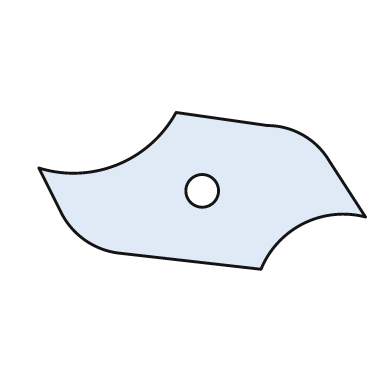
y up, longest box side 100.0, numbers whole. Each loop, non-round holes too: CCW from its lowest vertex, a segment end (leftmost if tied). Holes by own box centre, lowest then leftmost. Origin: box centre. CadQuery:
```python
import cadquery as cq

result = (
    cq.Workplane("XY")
    .moveTo(18.0, -24.0)
    .threePointArc((31.0, -10.0), (50.0, -8.0))
    .lineTo(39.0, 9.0)
    .threePointArc((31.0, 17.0), (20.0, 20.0))
    .lineTo(-8.0, 24.0)
    .threePointArc((-26.0, 8.0), (-50.0, 7.0))
    .lineTo(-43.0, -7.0)
    .threePointArc((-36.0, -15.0), (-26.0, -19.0))
    .close()
    .moveTo(0.0, 0.0)
    .circle(5.0)
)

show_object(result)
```